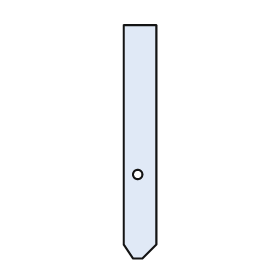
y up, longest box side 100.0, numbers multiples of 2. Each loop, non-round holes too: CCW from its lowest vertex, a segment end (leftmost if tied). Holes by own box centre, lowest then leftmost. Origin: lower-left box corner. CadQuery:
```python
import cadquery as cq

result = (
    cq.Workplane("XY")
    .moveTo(4.0, 0.0)
    .lineTo(8.0, 0.0)
    .lineTo(14.0, 6.0)
    .lineTo(14.0, 100.0)
    .lineTo(0.0, 100.0)
    .lineTo(0.0, 6.0)
    .close()
    .moveTo(6.0, 36.0)
    .circle(2.0)
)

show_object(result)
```